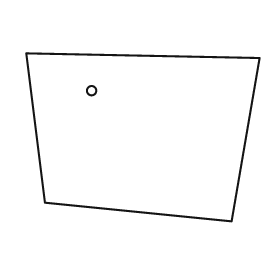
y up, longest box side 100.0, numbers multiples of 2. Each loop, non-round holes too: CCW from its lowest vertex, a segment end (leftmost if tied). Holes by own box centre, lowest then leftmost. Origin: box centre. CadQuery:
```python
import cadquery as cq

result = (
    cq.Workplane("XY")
    .moveTo(38.0, -36.0)
    .lineTo(50.0, 34.0)
    .lineTo(-50.0, 36.0)
    .lineTo(-42.0, -28.0)
    .close()
    .moveTo(-22.0, 20.0)
    .circle(2.0)
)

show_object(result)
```